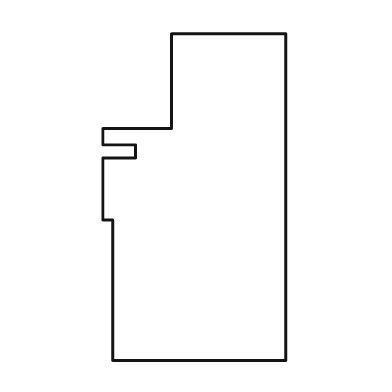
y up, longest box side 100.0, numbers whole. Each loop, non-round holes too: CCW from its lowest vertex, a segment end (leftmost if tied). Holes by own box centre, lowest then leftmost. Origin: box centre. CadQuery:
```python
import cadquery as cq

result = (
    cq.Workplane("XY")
    .moveTo(-25.0, -50.0)
    .lineTo(28.0, -50.0)
    .lineTo(28.0, 50.0)
    .lineTo(-7.0, 50.0)
    .lineTo(-7.0, 21.0)
    .lineTo(-28.0, 21.0)
    .lineTo(-28.0, 16.0)
    .lineTo(-18.0, 16.0)
    .lineTo(-18.0, 12.0)
    .lineTo(-28.0, 12.0)
    .lineTo(-28.0, -7.0)
    .lineTo(-25.0, -7.0)
    .close()
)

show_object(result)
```